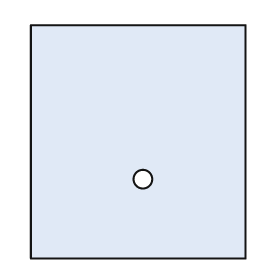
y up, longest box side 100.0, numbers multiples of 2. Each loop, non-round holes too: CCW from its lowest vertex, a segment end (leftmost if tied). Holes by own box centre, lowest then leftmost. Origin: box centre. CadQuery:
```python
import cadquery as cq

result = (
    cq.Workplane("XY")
    .moveTo(-46.0, -50.0)
    .lineTo(46.0, -50.0)
    .lineTo(46.0, 50.0)
    .lineTo(-46.0, 50.0)
    .close()
    .moveTo(2.0, -16.0)
    .circle(4.0)
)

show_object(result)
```